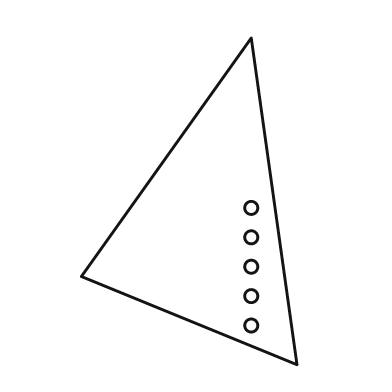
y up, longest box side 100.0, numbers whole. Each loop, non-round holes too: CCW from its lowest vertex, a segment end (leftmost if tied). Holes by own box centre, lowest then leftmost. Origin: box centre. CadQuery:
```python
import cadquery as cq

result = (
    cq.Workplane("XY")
    .moveTo(33.0, -50.0)
    .lineTo(19.0, 50.0)
    .lineTo(-33.0, -23.0)
    .close()
    .moveTo(19.0, -38.0)
    .circle(2.0)
    .moveTo(19.0, -29.0)
    .circle(2.0)
    .moveTo(19.0, -20.0)
    .circle(2.0)
    .moveTo(19.0, -11.0)
    .circle(2.0)
    .moveTo(19.0, -2.0)
    .circle(2.0)
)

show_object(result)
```